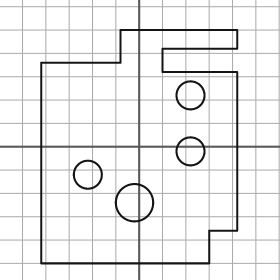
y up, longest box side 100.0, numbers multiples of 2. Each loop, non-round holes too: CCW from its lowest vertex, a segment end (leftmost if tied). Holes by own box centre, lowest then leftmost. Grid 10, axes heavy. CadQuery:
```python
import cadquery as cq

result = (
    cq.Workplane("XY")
    .moveTo(-42.0, -50.0)
    .lineTo(30.0, -50.0)
    .lineTo(30.0, -36.0)
    .lineTo(42.0, -36.0)
    .lineTo(42.0, 32.0)
    .lineTo(10.0, 32.0)
    .lineTo(10.0, 42.0)
    .lineTo(42.0, 42.0)
    .lineTo(42.0, 50.0)
    .lineTo(-8.0, 50.0)
    .lineTo(-8.0, 36.0)
    .lineTo(-42.0, 36.0)
    .close()
    .moveTo(-2.0, -24.0)
    .circle(8.0)
    .moveTo(-22.0, -12.0)
    .circle(6.0)
    .moveTo(22.0, -2.0)
    .circle(6.0)
    .moveTo(22.0, 22.0)
    .circle(6.0)
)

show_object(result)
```